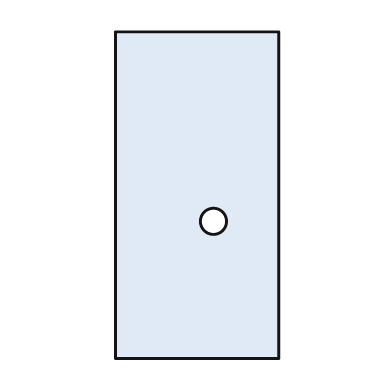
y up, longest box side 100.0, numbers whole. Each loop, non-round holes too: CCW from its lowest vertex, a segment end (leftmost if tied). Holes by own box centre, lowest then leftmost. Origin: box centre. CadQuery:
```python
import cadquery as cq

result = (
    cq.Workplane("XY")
    .moveTo(-25.0, -50.0)
    .lineTo(25.0, -50.0)
    .lineTo(25.0, 50.0)
    .lineTo(-25.0, 50.0)
    .close()
    .moveTo(5.0, -8.0)
    .circle(4.0)
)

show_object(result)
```